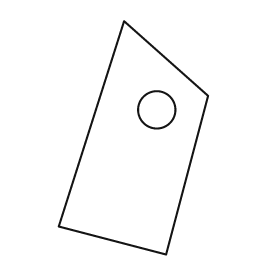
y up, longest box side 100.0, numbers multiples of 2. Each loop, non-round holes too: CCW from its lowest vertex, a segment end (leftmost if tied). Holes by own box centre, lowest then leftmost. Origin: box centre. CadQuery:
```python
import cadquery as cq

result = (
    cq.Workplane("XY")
    .moveTo(14.0, -50.0)
    .lineTo(32.0, 18.0)
    .lineTo(-4.0, 50.0)
    .lineTo(-32.0, -38.0)
    .close()
    .moveTo(10.0, 12.0)
    .circle(8.0)
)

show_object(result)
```